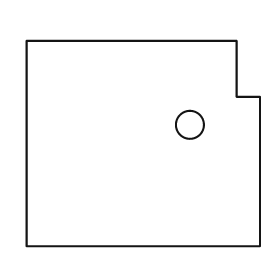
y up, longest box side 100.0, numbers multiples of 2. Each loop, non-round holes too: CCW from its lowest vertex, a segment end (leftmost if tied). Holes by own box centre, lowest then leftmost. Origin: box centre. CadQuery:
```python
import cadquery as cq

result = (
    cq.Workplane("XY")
    .moveTo(-50.0, -44.0)
    .lineTo(50.0, -44.0)
    .lineTo(50.0, 20.0)
    .lineTo(40.0, 20.0)
    .lineTo(40.0, 44.0)
    .lineTo(-50.0, 44.0)
    .close()
    .moveTo(20.0, 8.0)
    .circle(6.0)
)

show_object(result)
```